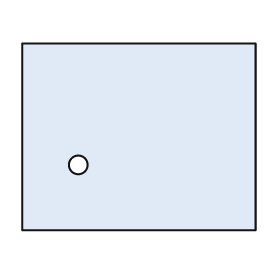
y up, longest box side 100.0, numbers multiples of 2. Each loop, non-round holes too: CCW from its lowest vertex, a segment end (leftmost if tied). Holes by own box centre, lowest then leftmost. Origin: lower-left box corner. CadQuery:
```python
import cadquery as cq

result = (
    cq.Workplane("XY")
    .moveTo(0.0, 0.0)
    .lineTo(100.0, 0.0)
    .lineTo(100.0, 80.0)
    .lineTo(0.0, 80.0)
    .close()
    .moveTo(24.0, 28.0)
    .circle(4.0)
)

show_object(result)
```